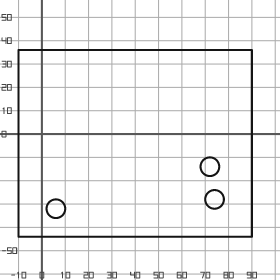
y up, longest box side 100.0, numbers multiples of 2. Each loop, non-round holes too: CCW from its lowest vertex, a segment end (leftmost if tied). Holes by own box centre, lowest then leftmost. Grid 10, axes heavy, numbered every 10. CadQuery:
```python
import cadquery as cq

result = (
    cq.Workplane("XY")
    .moveTo(-10.0, -44.0)
    .lineTo(90.0, -44.0)
    .lineTo(90.0, 36.0)
    .lineTo(-10.0, 36.0)
    .close()
    .moveTo(6.0, -32.0)
    .circle(4.0)
    .moveTo(74.0, -28.0)
    .circle(4.0)
    .moveTo(72.0, -14.0)
    .circle(4.0)
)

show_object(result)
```